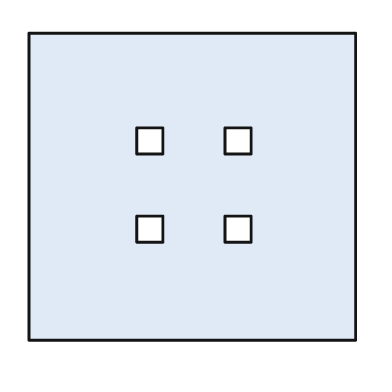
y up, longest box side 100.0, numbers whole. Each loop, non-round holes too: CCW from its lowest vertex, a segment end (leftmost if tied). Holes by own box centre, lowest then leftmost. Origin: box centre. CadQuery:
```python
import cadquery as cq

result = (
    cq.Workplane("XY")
    .moveTo(-50.0, -47.0)
    .lineTo(50.0, -47.0)
    .lineTo(50.0, 47.0)
    .lineTo(-50.0, 47.0)
    .close()
    .moveTo(-17.0, -17.0)
    .lineTo(-9.0, -17.0)
    .lineTo(-9.0, -9.0)
    .lineTo(-17.0, -9.0)
    .close()
    .moveTo(10.0, -17.0)
    .lineTo(18.0, -17.0)
    .lineTo(18.0, -9.0)
    .lineTo(10.0, -9.0)
    .close()
    .moveTo(-17.0, 10.0)
    .lineTo(-9.0, 10.0)
    .lineTo(-9.0, 18.0)
    .lineTo(-17.0, 18.0)
    .close()
    .moveTo(10.0, 10.0)
    .lineTo(18.0, 10.0)
    .lineTo(18.0, 18.0)
    .lineTo(10.0, 18.0)
    .close()
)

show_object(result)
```